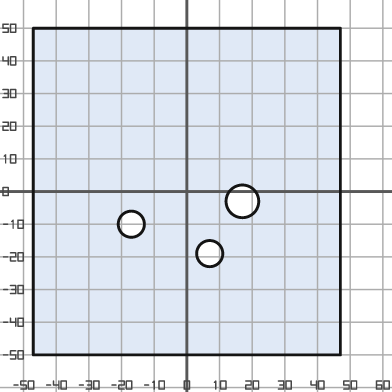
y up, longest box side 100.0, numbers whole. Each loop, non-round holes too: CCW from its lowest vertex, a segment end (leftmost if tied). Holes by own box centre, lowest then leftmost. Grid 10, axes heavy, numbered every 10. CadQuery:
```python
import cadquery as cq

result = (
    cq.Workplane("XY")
    .moveTo(-47.0, -50.0)
    .lineTo(47.0, -50.0)
    .lineTo(47.0, 50.0)
    .lineTo(-47.0, 50.0)
    .close()
    .moveTo(7.0, -19.0)
    .circle(4.0)
    .moveTo(-17.0, -10.0)
    .circle(4.0)
    .moveTo(17.0, -3.0)
    .circle(5.0)
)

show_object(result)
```